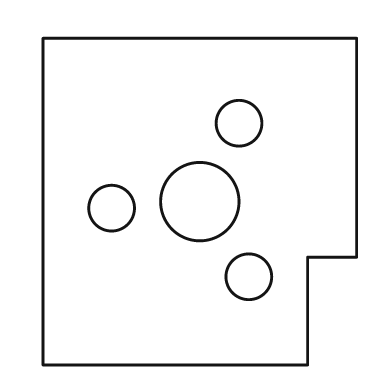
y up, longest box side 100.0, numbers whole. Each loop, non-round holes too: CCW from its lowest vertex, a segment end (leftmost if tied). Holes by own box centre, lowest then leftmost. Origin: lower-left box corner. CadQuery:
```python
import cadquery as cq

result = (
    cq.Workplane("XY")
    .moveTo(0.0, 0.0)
    .lineTo(81.0, 0.0)
    .lineTo(81.0, 33.0)
    .lineTo(96.0, 33.0)
    .lineTo(96.0, 100.0)
    .lineTo(0.0, 100.0)
    .close()
    .moveTo(63.0, 27.0)
    .circle(7.0)
    .moveTo(21.0, 48.0)
    .circle(7.0)
    .moveTo(48.0, 50.0)
    .circle(12.0)
    .moveTo(60.0, 74.0)
    .circle(7.0)
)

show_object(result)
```